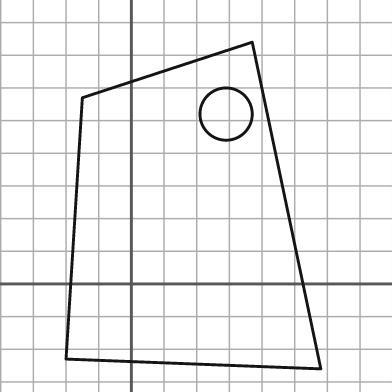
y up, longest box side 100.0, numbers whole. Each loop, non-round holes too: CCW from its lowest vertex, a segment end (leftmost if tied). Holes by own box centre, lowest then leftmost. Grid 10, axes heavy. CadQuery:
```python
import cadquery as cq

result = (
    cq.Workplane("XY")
    .moveTo(58.0, -26.0)
    .lineTo(37.0, 74.0)
    .lineTo(-15.0, 57.0)
    .lineTo(-20.0, -23.0)
    .close()
    .moveTo(29.0, 52.0)
    .circle(8.0)
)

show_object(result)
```